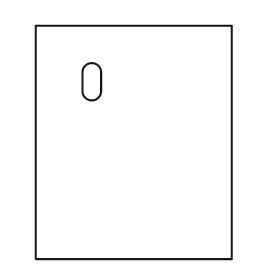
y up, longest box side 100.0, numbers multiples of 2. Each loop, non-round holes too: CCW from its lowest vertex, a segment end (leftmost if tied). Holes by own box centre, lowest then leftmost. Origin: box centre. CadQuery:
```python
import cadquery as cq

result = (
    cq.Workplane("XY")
    .moveTo(-42.0, -50.0)
    .lineTo(42.0, -50.0)
    .lineTo(42.0, 50.0)
    .lineTo(-42.0, 50.0)
    .close()
    .moveTo(-22.0, 22.0)
    .threePointArc((-18.0, 18.0), (-14.0, 22.0))
    .lineTo(-14.0, 30.0)
    .threePointArc((-18.0, 34.0), (-22.0, 30.0))
    .close()
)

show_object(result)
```